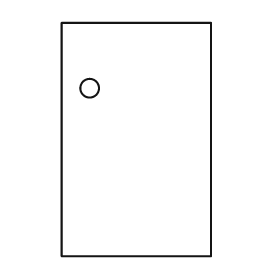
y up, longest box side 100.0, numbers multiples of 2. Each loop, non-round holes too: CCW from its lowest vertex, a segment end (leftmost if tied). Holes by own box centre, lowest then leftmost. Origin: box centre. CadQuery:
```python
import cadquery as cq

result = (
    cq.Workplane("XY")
    .moveTo(-32.0, -50.0)
    .lineTo(32.0, -50.0)
    .lineTo(32.0, 50.0)
    .lineTo(-32.0, 50.0)
    .close()
    .moveTo(-20.0, 22.0)
    .circle(4.0)
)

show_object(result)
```